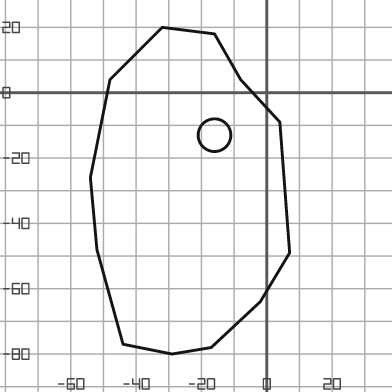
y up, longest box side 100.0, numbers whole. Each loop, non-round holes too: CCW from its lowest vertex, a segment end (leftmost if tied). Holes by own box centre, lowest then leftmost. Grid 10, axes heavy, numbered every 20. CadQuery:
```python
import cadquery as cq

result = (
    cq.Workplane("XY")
    .moveTo(-29.0, -80.0)
    .lineTo(-17.0, -78.0)
    .lineTo(-2.0, -64.0)
    .lineTo(7.0, -49.0)
    .lineTo(4.0, -9.0)
    .lineTo(-8.0, 4.0)
    .lineTo(-16.0, 18.0)
    .lineTo(-32.0, 20.0)
    .lineTo(-48.0, 4.0)
    .lineTo(-54.0, -26.0)
    .lineTo(-52.0, -48.0)
    .lineTo(-44.0, -77.0)
    .close()
    .moveTo(-16.0, -13.0)
    .circle(5.0)
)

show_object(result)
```